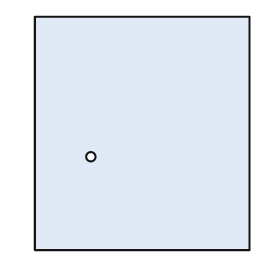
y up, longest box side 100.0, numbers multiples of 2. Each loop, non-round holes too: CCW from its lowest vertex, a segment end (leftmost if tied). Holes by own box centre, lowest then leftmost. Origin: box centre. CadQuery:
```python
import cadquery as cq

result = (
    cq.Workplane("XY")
    .moveTo(-46.0, -50.0)
    .lineTo(46.0, -50.0)
    .lineTo(46.0, 50.0)
    .lineTo(-46.0, 50.0)
    .close()
    .moveTo(-22.0, -10.0)
    .circle(2.0)
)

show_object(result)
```